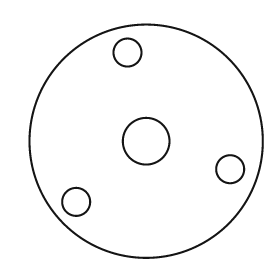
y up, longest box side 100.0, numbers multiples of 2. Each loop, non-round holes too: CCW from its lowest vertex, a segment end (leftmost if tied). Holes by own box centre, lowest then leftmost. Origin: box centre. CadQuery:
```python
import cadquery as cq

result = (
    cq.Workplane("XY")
    .moveTo(0.0, 0.0)
    .circle(50.0)
    .moveTo(-30.0, -26.0)
    .circle(6.0)
    .moveTo(36.0, -12.0)
    .circle(6.0)
    .moveTo(0.0, 0.0)
    .circle(10.0)
    .moveTo(-8.0, 38.0)
    .circle(6.0)
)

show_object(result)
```